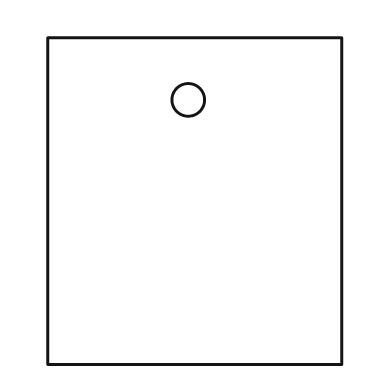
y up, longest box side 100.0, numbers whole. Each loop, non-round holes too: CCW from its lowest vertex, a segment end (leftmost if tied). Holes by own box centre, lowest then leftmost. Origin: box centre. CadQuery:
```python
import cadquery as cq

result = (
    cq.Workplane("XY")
    .moveTo(-45.0, -50.0)
    .lineTo(45.0, -50.0)
    .lineTo(45.0, 50.0)
    .lineTo(-45.0, 50.0)
    .close()
    .moveTo(-2.0, 31.0)
    .circle(5.0)
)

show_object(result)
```